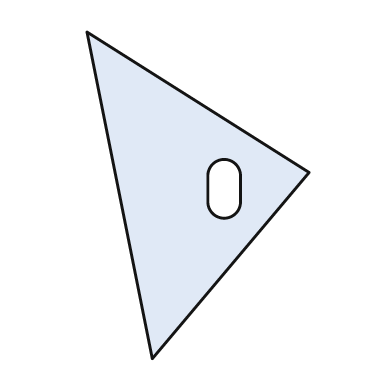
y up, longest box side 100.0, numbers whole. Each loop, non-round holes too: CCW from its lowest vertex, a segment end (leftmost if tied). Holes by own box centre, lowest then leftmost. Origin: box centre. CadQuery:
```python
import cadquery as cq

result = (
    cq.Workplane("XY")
    .moveTo(-14.0, -50.0)
    .lineTo(34.0, 7.0)
    .lineTo(-34.0, 50.0)
    .close()
    .moveTo(3.0, -2.0)
    .threePointArc((8.0, -7.0), (13.0, -2.0))
    .lineTo(13.0, 6.0)
    .threePointArc((8.0, 11.0), (3.0, 6.0))
    .close()
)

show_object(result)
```